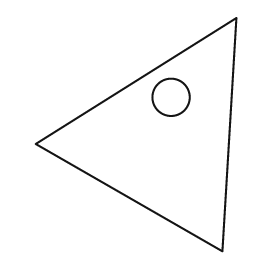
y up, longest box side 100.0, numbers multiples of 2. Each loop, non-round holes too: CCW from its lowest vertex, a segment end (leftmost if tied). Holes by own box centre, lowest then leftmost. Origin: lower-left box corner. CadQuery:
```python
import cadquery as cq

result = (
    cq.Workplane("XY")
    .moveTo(80.0, 0.0)
    .lineTo(86.0, 100.0)
    .lineTo(0.0, 46.0)
    .close()
    .moveTo(58.0, 66.0)
    .circle(8.0)
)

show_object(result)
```